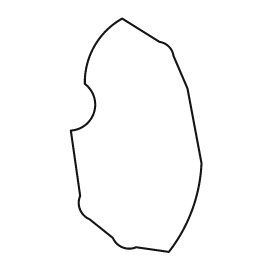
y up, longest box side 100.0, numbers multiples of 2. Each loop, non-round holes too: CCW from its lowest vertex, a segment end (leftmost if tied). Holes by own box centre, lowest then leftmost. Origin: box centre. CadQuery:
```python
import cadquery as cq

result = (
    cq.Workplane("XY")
    .moveTo(14.0, -50.0)
    .threePointArc((24.0, -32.0), (28.0, -12.0))
    .lineTo(22.0, 20.0)
    .lineTo(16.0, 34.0)
    .threePointArc((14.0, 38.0), (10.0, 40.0))
    .lineTo(-6.0, 50.0)
    .threePointArc((-18.0, 38.0), (-22.0, 22.0))
    .threePointArc((-18.0, 10.0), (-28.0, 2.0))
    .lineTo(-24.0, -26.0)
    .threePointArc((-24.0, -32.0), (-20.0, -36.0))
    .lineTo(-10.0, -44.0)
    .threePointArc((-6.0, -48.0), (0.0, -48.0))
    .close()
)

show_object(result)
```